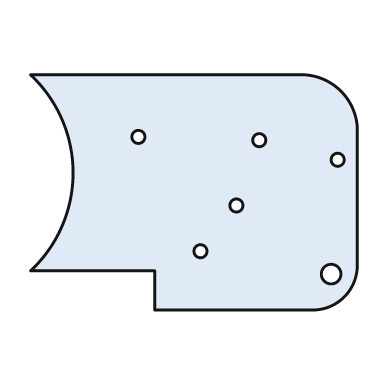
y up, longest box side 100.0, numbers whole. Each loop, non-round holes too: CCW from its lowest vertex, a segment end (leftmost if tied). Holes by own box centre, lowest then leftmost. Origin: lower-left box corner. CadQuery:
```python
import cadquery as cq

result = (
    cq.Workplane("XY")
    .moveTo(38.0, 0.0)
    .lineTo(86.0, 0.0)
    .threePointArc((96.0, 4.0), (100.0, 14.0))
    .lineTo(100.0, 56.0)
    .threePointArc((95.0, 67.0), (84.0, 72.0))
    .lineTo(0.0, 72.0)
    .threePointArc((13.0, 42.0), (0.0, 12.0))
    .lineTo(38.0, 12.0)
    .close()
    .moveTo(92.0, 11.0)
    .circle(3.0)
    .moveTo(52.0, 18.0)
    .circle(2.0)
    .moveTo(63.0, 32.0)
    .circle(2.0)
    .moveTo(94.0, 46.0)
    .circle(2.0)
    .moveTo(70.0, 52.0)
    .circle(2.0)
    .moveTo(33.0, 53.0)
    .circle(2.0)
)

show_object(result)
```